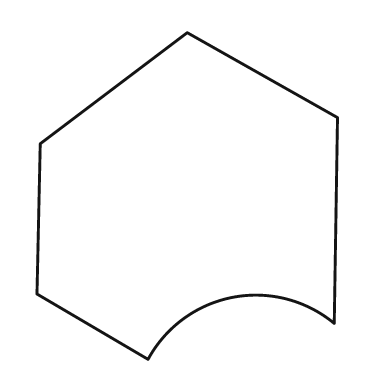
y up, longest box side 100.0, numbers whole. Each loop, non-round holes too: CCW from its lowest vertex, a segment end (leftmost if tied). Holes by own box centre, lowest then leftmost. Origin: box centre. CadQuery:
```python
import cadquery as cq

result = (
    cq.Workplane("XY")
    .moveTo(-12.0, -50.0)
    .threePointArc((14.0, -31.0), (45.0, -39.0))
    .lineTo(46.0, 24.0)
    .lineTo(0.0, 50.0)
    .lineTo(-45.0, 16.0)
    .lineTo(-46.0, -30.0)
    .close()
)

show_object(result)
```